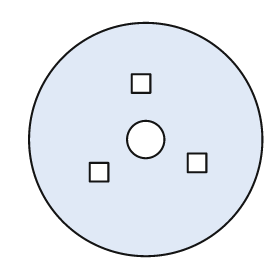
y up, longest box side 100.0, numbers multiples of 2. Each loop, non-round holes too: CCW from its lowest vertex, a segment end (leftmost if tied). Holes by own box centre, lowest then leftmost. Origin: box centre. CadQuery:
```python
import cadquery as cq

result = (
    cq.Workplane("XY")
    .moveTo(0.0, 0.0)
    .circle(50.0)
    .moveTo(-24.0, -18.0)
    .lineTo(-16.0, -18.0)
    .lineTo(-16.0, -10.0)
    .lineTo(-24.0, -10.0)
    .close()
    .moveTo(18.0, -14.0)
    .lineTo(26.0, -14.0)
    .lineTo(26.0, -6.0)
    .lineTo(18.0, -6.0)
    .close()
    .moveTo(0.0, 0.0)
    .circle(8.0)
    .moveTo(-6.0, 20.0)
    .lineTo(2.0, 20.0)
    .lineTo(2.0, 28.0)
    .lineTo(-6.0, 28.0)
    .close()
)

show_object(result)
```